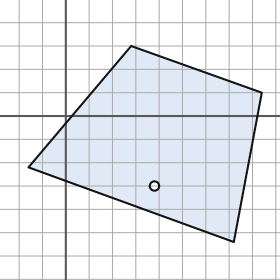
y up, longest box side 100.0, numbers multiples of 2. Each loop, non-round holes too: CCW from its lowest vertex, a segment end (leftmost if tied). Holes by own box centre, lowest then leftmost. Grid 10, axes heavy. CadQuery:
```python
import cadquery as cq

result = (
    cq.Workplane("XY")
    .moveTo(72.0, -54.0)
    .lineTo(84.0, 10.0)
    .lineTo(28.0, 30.0)
    .lineTo(-16.0, -22.0)
    .close()
    .moveTo(38.0, -30.0)
    .circle(2.0)
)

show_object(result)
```